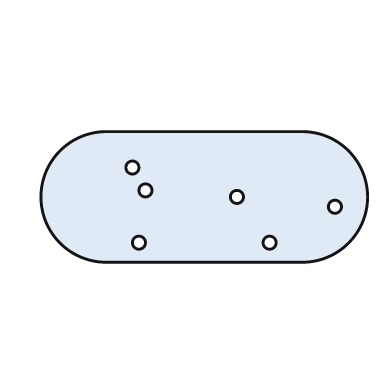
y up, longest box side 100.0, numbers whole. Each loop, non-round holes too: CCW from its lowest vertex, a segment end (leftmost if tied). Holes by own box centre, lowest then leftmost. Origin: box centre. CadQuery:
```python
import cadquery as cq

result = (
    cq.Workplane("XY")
    .moveTo(-30.0, -20.0)
    .lineTo(30.0, -20.0)
    .threePointArc((50.0, 0.0), (30.0, 20.0))
    .lineTo(-30.0, 20.0)
    .threePointArc((-50.0, 0.0), (-30.0, -20.0))
    .close()
    .moveTo(-20.0, -14.0)
    .circle(2.0)
    .moveTo(20.0, -14.0)
    .circle(2.0)
    .moveTo(40.0, -3.0)
    .circle(2.0)
    .moveTo(10.0, 0.0)
    .circle(2.0)
    .moveTo(-18.0, 2.0)
    .circle(2.0)
    .moveTo(-22.0, 9.0)
    .circle(2.0)
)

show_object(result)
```